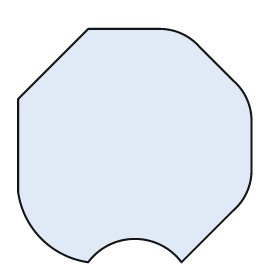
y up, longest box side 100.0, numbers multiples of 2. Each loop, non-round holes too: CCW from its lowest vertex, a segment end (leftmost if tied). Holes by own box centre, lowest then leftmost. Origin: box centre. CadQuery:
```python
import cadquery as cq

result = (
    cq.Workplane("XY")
    .moveTo(-20.0, -50.0)
    .threePointArc((0.0, -40.0), (20.0, -50.0))
    .lineTo(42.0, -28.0)
    .threePointArc((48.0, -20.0), (50.0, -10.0))
    .lineTo(50.0, 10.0)
    .threePointArc((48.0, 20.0), (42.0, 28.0))
    .lineTo(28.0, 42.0)
    .threePointArc((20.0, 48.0), (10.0, 50.0))
    .lineTo(-20.0, 50.0)
    .lineTo(-50.0, 20.0)
    .lineTo(-50.0, -20.0)
    .threePointArc((-40.0, -40.0), (-20.0, -50.0))
    .close()
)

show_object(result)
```